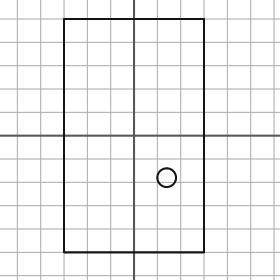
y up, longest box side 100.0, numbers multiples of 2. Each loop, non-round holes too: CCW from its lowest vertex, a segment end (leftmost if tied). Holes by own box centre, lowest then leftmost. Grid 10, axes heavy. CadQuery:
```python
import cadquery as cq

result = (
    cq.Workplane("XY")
    .moveTo(-30.0, -50.0)
    .lineTo(30.0, -50.0)
    .lineTo(30.0, 50.0)
    .lineTo(-30.0, 50.0)
    .close()
    .moveTo(14.0, -18.0)
    .circle(4.0)
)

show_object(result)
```